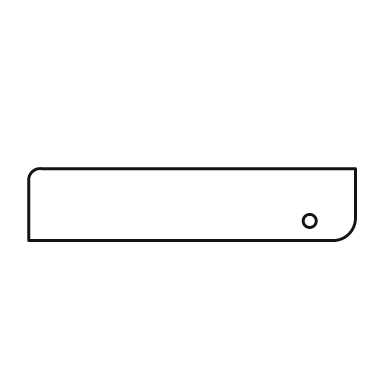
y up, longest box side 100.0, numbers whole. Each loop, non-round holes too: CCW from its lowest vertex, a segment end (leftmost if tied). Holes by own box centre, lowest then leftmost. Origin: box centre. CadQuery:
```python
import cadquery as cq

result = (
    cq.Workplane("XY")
    .moveTo(-50.0, -11.0)
    .lineTo(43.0, -11.0)
    .threePointArc((48.0, -9.0), (50.0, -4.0))
    .lineTo(50.0, 11.0)
    .lineTo(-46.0, 11.0)
    .threePointArc((-49.0, 10.0), (-50.0, 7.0))
    .close()
    .moveTo(36.0, -5.0)
    .circle(2.0)
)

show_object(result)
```